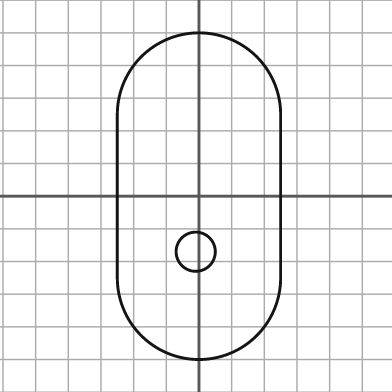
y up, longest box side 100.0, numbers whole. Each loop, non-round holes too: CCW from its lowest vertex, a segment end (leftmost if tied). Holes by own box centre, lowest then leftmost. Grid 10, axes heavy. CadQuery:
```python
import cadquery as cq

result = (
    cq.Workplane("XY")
    .moveTo(-25.0, -25.0)
    .threePointArc((0.0, -50.0), (25.0, -25.0))
    .lineTo(25.0, 25.0)
    .threePointArc((0.0, 50.0), (-25.0, 25.0))
    .close()
    .moveTo(-1.0, -17.0)
    .circle(6.0)
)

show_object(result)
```